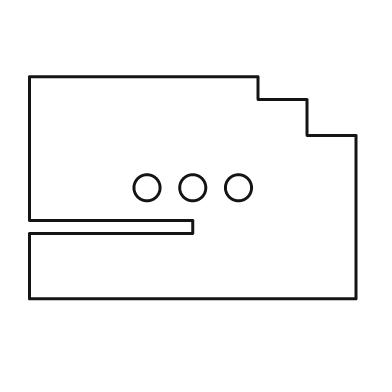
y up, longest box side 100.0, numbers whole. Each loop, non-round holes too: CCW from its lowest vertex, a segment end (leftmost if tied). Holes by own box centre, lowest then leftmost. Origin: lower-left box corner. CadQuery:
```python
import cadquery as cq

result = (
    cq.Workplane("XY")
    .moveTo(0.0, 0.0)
    .lineTo(100.0, 0.0)
    .lineTo(100.0, 50.0)
    .lineTo(85.0, 50.0)
    .lineTo(85.0, 61.0)
    .lineTo(70.0, 61.0)
    .lineTo(70.0, 68.0)
    .lineTo(0.0, 68.0)
    .lineTo(0.0, 24.0)
    .lineTo(50.0, 24.0)
    .lineTo(50.0, 20.0)
    .lineTo(0.0, 20.0)
    .close()
    .moveTo(36.0, 34.0)
    .circle(4.0)
    .moveTo(50.0, 34.0)
    .circle(4.0)
    .moveTo(64.0, 34.0)
    .circle(4.0)
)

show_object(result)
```